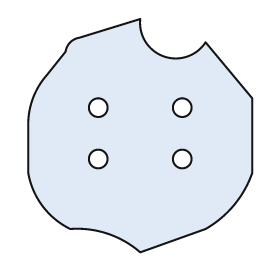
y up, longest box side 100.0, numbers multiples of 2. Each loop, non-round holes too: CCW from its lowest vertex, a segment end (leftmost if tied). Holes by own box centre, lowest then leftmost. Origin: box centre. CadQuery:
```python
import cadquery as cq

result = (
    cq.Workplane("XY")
    .moveTo(0.0, -50.0)
    .lineTo(28.0, -40.0)
    .threePointArc((40.0, -30.0), (48.0, -16.0))
    .lineTo(48.0, 16.0)
    .lineTo(28.0, 40.0)
    .threePointArc((10.0, 34.0), (0.0, 50.0))
    .lineTo(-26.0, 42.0)
    .threePointArc((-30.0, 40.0), (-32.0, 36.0))
    .lineTo(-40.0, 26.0)
    .threePointArc((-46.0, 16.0), (-48.0, 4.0))
    .lineTo(-48.0, -16.0)
    .threePointArc((-42.0, -30.0), (-30.0, -40.0))
    .threePointArc((-14.0, -42.0), (0.0, -50.0))
    .close()
    .moveTo(-18.0, -10.0)
    .circle(4.0)
    .moveTo(18.0, -10.0)
    .circle(4.0)
    .moveTo(-18.0, 12.0)
    .circle(4.0)
    .moveTo(18.0, 12.0)
    .circle(4.0)
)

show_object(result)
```